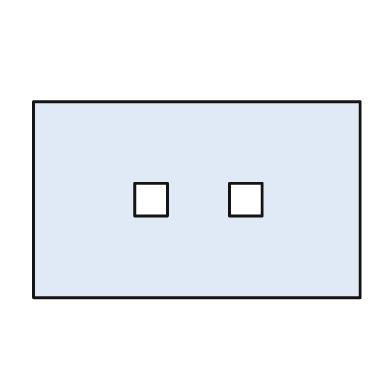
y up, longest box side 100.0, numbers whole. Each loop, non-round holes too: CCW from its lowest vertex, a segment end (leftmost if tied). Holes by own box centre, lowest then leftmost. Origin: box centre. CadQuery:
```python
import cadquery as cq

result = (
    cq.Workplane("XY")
    .moveTo(-50.0, -30.0)
    .lineTo(50.0, -30.0)
    .lineTo(50.0, 30.0)
    .lineTo(-50.0, 30.0)
    .close()
    .moveTo(-19.0, -5.0)
    .lineTo(-9.0, -5.0)
    .lineTo(-9.0, 5.0)
    .lineTo(-19.0, 5.0)
    .close()
    .moveTo(10.0, -5.0)
    .lineTo(20.0, -5.0)
    .lineTo(20.0, 5.0)
    .lineTo(10.0, 5.0)
    .close()
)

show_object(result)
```